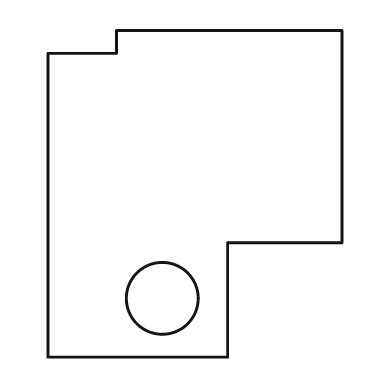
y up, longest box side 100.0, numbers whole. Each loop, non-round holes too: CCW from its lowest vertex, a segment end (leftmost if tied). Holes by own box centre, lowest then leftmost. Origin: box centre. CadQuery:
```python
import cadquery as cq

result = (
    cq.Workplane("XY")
    .moveTo(-45.0, -50.0)
    .lineTo(10.0, -50.0)
    .lineTo(10.0, -15.0)
    .lineTo(45.0, -15.0)
    .lineTo(45.0, 50.0)
    .lineTo(-24.0, 50.0)
    .lineTo(-24.0, 43.0)
    .lineTo(-45.0, 43.0)
    .close()
    .moveTo(-10.0, -32.0)
    .circle(11.0)
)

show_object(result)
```